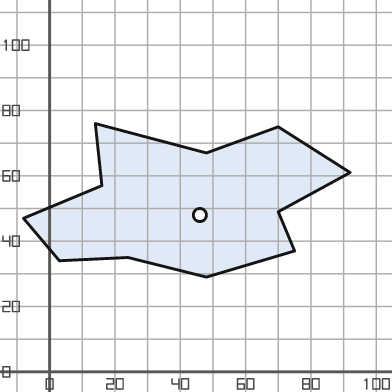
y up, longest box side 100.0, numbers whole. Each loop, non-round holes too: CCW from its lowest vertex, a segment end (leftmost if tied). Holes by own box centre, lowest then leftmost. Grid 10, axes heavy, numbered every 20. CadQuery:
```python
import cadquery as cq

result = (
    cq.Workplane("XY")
    .moveTo(48.0, 29.0)
    .lineTo(75.0, 37.0)
    .lineTo(70.0, 49.0)
    .lineTo(92.0, 61.0)
    .lineTo(70.0, 75.0)
    .lineTo(48.0, 67.0)
    .lineTo(14.0, 76.0)
    .lineTo(16.0, 57.0)
    .lineTo(-8.0, 47.0)
    .lineTo(3.0, 34.0)
    .lineTo(24.0, 35.0)
    .close()
    .moveTo(46.0, 48.0)
    .circle(2.0)
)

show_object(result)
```